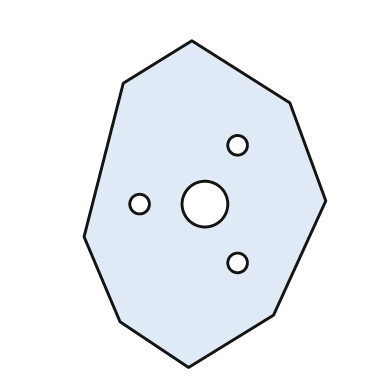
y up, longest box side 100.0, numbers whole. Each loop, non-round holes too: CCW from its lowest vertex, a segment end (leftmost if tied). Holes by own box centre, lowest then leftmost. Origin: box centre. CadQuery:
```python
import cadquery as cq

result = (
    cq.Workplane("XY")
    .moveTo(-5.0, -50.0)
    .lineTo(21.0, -34.0)
    .lineTo(37.0, 1.0)
    .lineTo(26.0, 31.0)
    .lineTo(-4.0, 50.0)
    .lineTo(-25.0, 37.0)
    .lineTo(-37.0, -10.0)
    .lineTo(-26.0, -36.0)
    .close()
    .moveTo(10.0, -18.0)
    .circle(3.0)
    .moveTo(-20.0, 0.0)
    .circle(3.0)
    .moveTo(0.0, 0.0)
    .circle(7.0)
    .moveTo(10.0, 18.0)
    .circle(3.0)
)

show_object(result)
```